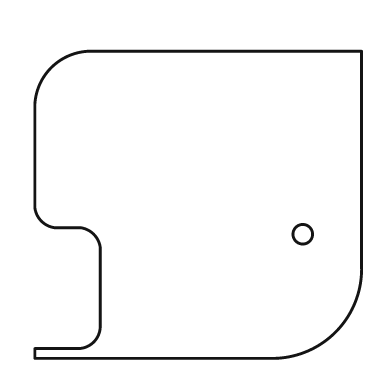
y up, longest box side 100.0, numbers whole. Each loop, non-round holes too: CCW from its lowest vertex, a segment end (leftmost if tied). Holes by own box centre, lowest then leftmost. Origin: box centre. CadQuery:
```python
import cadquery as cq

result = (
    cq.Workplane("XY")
    .moveTo(-50.0, -47.0)
    .lineTo(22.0, -47.0)
    .threePointArc((42.0, -39.0), (50.0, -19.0))
    .lineTo(50.0, 47.0)
    .lineTo(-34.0, 47.0)
    .threePointArc((-45.0, 42.0), (-50.0, 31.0))
    .lineTo(-50.0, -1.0)
    .threePointArc((-48.0, -5.0), (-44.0, -7.0))
    .lineTo(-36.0, -7.0)
    .threePointArc((-32.0, -9.0), (-30.0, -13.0))
    .lineTo(-30.0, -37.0)
    .threePointArc((-32.0, -42.0), (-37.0, -44.0))
    .lineTo(-50.0, -44.0)
    .close()
    .moveTo(32.0, -9.0)
    .circle(3.0)
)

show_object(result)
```